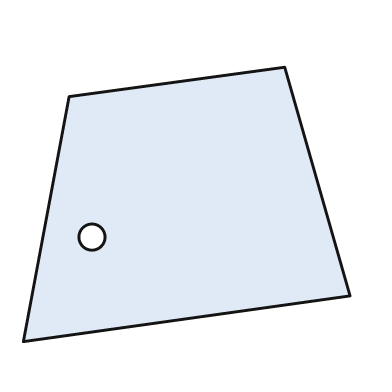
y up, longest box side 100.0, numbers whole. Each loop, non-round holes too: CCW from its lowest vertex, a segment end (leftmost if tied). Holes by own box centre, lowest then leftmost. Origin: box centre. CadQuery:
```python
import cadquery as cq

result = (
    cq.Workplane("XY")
    .moveTo(-50.0, -42.0)
    .lineTo(50.0, -28.0)
    .lineTo(30.0, 42.0)
    .lineTo(-36.0, 33.0)
    .close()
    .moveTo(-29.0, -10.0)
    .circle(4.0)
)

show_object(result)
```